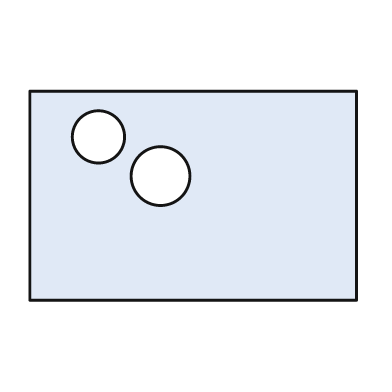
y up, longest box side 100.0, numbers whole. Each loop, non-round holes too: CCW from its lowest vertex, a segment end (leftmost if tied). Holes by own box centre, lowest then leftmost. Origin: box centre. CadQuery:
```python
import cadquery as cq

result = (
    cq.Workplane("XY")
    .moveTo(-50.0, -32.0)
    .lineTo(50.0, -32.0)
    .lineTo(50.0, 32.0)
    .lineTo(-50.0, 32.0)
    .close()
    .moveTo(-10.0, 6.0)
    .circle(9.0)
    .moveTo(-29.0, 18.0)
    .circle(8.0)
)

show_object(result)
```